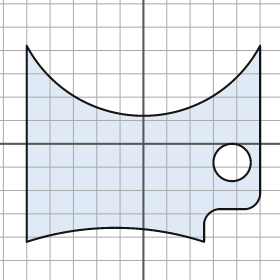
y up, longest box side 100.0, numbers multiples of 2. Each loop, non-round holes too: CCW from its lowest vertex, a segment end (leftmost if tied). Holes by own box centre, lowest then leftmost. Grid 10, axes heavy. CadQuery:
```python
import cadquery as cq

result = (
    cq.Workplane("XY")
    .moveTo(-50.0, -42.0)
    .threePointArc((-12.0, -36.0), (26.0, -42.0))
    .lineTo(26.0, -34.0)
    .threePointArc((28.0, -30.0), (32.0, -28.0))
    .lineTo(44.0, -28.0)
    .threePointArc((48.0, -26.0), (50.0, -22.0))
    .lineTo(50.0, 42.0)
    .threePointArc((0.0, 12.0), (-50.0, 42.0))
    .close()
    .moveTo(38.0, -8.0)
    .circle(8.0)
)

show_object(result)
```